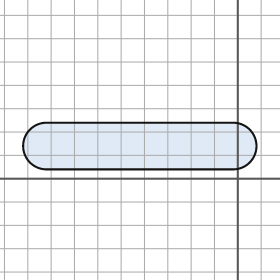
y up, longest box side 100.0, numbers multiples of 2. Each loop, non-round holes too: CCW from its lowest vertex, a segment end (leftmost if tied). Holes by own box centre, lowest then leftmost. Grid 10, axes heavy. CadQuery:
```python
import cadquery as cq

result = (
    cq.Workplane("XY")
    .moveTo(-82.0, 4.0)
    .lineTo(-2.0, 4.0)
    .threePointArc((8.0, 14.0), (-2.0, 24.0))
    .lineTo(-82.0, 24.0)
    .threePointArc((-92.0, 14.0), (-82.0, 4.0))
    .close()
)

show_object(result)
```